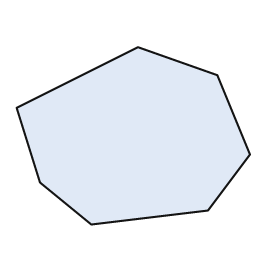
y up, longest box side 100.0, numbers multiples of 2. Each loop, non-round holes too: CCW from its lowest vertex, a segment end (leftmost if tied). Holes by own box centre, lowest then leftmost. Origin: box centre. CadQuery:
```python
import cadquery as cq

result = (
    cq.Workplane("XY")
    .moveTo(-18.0, -38.0)
    .lineTo(32.0, -32.0)
    .lineTo(50.0, -8.0)
    .lineTo(36.0, 26.0)
    .lineTo(2.0, 38.0)
    .lineTo(-50.0, 12.0)
    .lineTo(-40.0, -20.0)
    .close()
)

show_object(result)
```